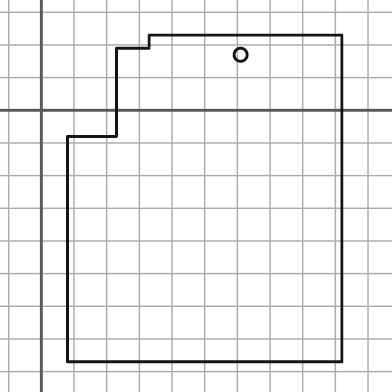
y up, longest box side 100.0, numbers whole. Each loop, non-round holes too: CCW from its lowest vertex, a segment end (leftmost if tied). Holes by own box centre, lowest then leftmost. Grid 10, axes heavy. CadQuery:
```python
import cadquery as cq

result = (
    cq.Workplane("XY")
    .moveTo(8.0, -77.0)
    .lineTo(92.0, -77.0)
    .lineTo(92.0, 23.0)
    .lineTo(33.0, 23.0)
    .lineTo(33.0, 19.0)
    .lineTo(23.0, 19.0)
    .lineTo(23.0, -8.0)
    .lineTo(8.0, -8.0)
    .close()
    .moveTo(61.0, 17.0)
    .circle(2.0)
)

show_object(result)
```